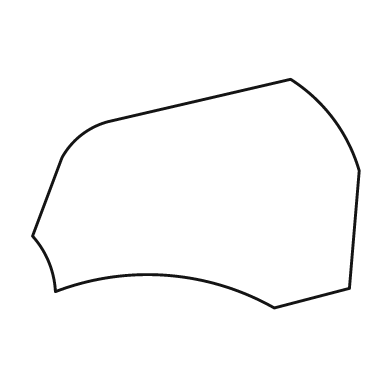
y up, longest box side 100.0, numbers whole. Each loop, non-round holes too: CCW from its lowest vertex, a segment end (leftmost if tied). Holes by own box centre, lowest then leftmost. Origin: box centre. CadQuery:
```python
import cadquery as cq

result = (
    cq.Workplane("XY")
    .moveTo(24.0, -35.0)
    .lineTo(47.0, -29.0)
    .lineTo(50.0, 7.0)
    .threePointArc((42.0, 23.0), (29.0, 35.0))
    .lineTo(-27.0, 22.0)
    .threePointArc((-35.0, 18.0), (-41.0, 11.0))
    .lineTo(-50.0, -13.0)
    .threePointArc((-45.0, -21.0), (-43.0, -30.0))
    .threePointArc((-9.0, -25.0), (24.0, -35.0))
    .close()
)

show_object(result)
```